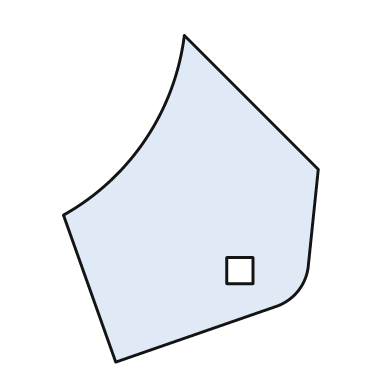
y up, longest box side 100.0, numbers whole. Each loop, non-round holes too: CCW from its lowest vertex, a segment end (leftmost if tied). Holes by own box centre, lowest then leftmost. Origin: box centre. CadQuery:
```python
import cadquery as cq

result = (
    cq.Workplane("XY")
    .moveTo(-23.0, -50.0)
    .lineTo(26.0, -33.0)
    .threePointArc((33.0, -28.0), (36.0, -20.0))
    .lineTo(39.0, 9.0)
    .lineTo(-2.0, 50.0)
    .threePointArc((-14.0, 18.0), (-39.0, -5.0))
    .close()
    .moveTo(11.0, -26.0)
    .lineTo(19.0, -26.0)
    .lineTo(19.0, -18.0)
    .lineTo(11.0, -18.0)
    .close()
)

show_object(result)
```